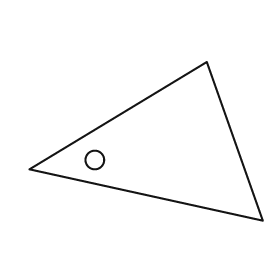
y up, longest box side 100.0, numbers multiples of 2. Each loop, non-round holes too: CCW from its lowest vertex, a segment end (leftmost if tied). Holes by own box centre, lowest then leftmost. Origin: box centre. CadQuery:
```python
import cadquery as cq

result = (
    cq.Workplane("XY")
    .moveTo(50.0, -34.0)
    .lineTo(26.0, 34.0)
    .lineTo(-50.0, -12.0)
    .close()
    .moveTo(-22.0, -8.0)
    .circle(4.0)
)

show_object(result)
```